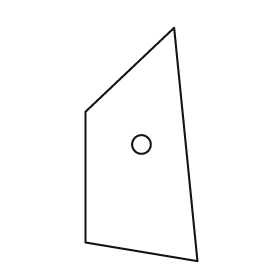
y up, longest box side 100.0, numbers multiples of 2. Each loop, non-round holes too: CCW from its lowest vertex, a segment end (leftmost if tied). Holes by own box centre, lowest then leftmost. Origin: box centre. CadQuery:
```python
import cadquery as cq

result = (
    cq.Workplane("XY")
    .moveTo(24.0, -50.0)
    .lineTo(14.0, 50.0)
    .lineTo(-24.0, 14.0)
    .lineTo(-24.0, -42.0)
    .close()
    .moveTo(0.0, 0.0)
    .circle(4.0)
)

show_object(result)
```